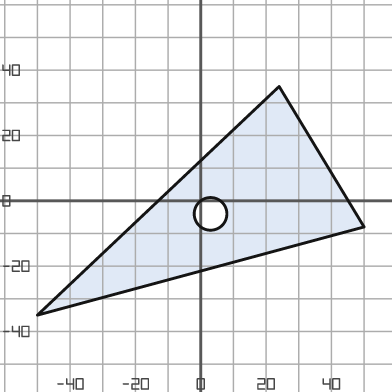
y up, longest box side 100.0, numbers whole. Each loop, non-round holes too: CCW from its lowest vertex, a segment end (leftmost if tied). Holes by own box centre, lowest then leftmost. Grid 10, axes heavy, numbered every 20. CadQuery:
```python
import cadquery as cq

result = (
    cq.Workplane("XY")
    .moveTo(-50.0, -35.0)
    .lineTo(50.0, -8.0)
    .lineTo(24.0, 35.0)
    .close()
    .moveTo(3.0, -4.0)
    .circle(5.0)
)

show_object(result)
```